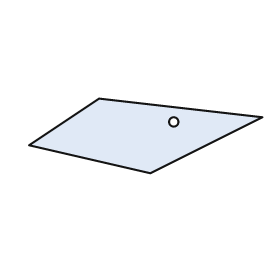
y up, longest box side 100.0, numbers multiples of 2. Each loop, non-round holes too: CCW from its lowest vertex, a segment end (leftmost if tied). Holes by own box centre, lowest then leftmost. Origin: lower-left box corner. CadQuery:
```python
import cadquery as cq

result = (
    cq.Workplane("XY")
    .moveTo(52.0, 0.0)
    .lineTo(100.0, 24.0)
    .lineTo(30.0, 32.0)
    .lineTo(0.0, 12.0)
    .close()
    .moveTo(62.0, 22.0)
    .circle(2.0)
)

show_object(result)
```